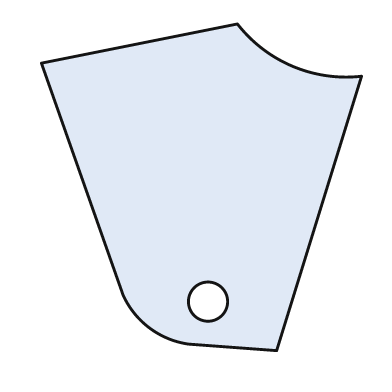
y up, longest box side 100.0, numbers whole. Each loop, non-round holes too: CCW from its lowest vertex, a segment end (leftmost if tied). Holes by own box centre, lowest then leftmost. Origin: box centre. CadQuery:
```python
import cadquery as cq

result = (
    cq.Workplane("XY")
    .moveTo(23.0, -50.0)
    .lineTo(49.0, 34.0)
    .threePointArc((28.0, 37.0), (11.0, 50.0))
    .lineTo(-49.0, 38.0)
    .lineTo(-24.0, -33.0)
    .threePointArc((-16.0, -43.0), (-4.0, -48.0))
    .close()
    .moveTo(2.0, -35.0)
    .circle(6.0)
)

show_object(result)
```